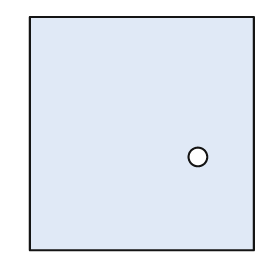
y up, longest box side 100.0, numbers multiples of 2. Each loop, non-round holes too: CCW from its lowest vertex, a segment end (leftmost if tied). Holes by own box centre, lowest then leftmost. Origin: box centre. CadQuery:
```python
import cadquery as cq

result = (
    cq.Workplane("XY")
    .moveTo(-48.0, -50.0)
    .lineTo(48.0, -50.0)
    .lineTo(48.0, 50.0)
    .lineTo(-48.0, 50.0)
    .close()
    .moveTo(24.0, -10.0)
    .circle(4.0)
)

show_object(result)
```